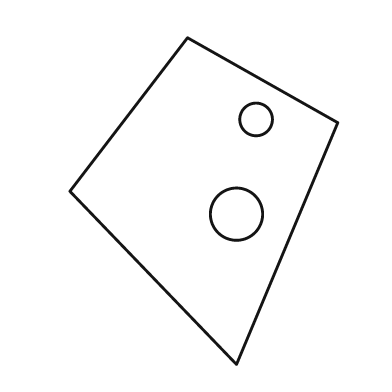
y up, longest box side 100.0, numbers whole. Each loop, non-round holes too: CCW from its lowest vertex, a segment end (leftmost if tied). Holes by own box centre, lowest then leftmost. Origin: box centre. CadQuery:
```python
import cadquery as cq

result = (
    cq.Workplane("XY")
    .moveTo(10.0, -50.0)
    .lineTo(41.0, 24.0)
    .lineTo(-5.0, 50.0)
    .lineTo(-41.0, 3.0)
    .close()
    .moveTo(10.0, -4.0)
    .circle(8.0)
    .moveTo(16.0, 25.0)
    .circle(5.0)
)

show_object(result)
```